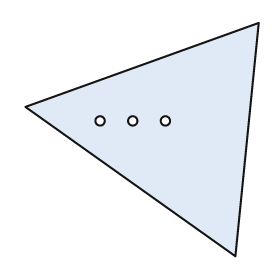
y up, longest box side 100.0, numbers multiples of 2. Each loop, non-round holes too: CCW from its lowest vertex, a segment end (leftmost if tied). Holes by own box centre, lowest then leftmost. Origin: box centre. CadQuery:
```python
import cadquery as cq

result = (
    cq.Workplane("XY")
    .moveTo(40.0, -50.0)
    .lineTo(50.0, 50.0)
    .lineTo(-50.0, 14.0)
    .close()
    .moveTo(-18.0, 8.0)
    .circle(2.0)
    .moveTo(-4.0, 8.0)
    .circle(2.0)
    .moveTo(10.0, 8.0)
    .circle(2.0)
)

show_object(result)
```